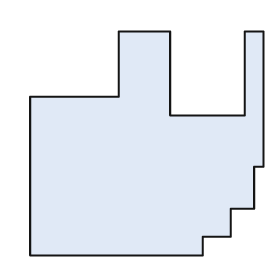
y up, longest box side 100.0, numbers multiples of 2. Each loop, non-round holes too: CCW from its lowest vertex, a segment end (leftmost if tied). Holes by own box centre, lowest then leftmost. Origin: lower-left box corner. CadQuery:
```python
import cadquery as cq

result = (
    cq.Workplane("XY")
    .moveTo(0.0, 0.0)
    .lineTo(74.0, 0.0)
    .lineTo(74.0, 8.0)
    .lineTo(86.0, 8.0)
    .lineTo(86.0, 20.0)
    .lineTo(96.0, 20.0)
    .lineTo(96.0, 38.0)
    .lineTo(100.0, 38.0)
    .lineTo(100.0, 96.0)
    .lineTo(92.0, 96.0)
    .lineTo(92.0, 60.0)
    .lineTo(60.0, 60.0)
    .lineTo(60.0, 96.0)
    .lineTo(38.0, 96.0)
    .lineTo(38.0, 68.0)
    .lineTo(0.0, 68.0)
    .close()
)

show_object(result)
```